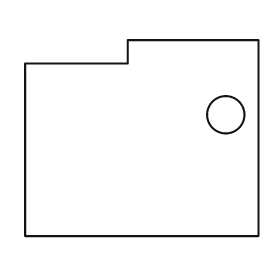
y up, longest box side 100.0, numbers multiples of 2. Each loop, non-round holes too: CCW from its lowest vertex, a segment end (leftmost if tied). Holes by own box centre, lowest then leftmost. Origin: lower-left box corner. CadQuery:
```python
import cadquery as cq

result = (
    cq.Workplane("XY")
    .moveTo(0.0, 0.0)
    .lineTo(100.0, 0.0)
    .lineTo(100.0, 84.0)
    .lineTo(44.0, 84.0)
    .lineTo(44.0, 74.0)
    .lineTo(0.0, 74.0)
    .close()
    .moveTo(86.0, 52.0)
    .circle(8.0)
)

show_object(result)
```